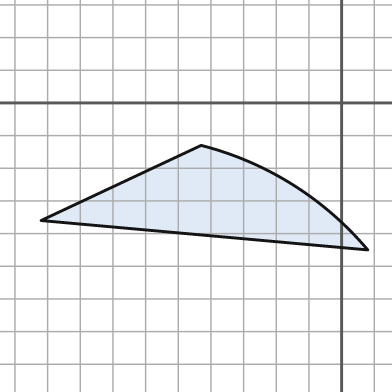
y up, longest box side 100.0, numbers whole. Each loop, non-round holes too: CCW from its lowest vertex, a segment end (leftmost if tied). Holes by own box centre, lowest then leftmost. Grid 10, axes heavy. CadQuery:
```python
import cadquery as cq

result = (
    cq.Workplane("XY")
    .moveTo(8.0, -45.0)
    .threePointArc((-15.0, -25.0), (-43.0, -13.0))
    .lineTo(-92.0, -36.0)
    .close()
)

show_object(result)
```